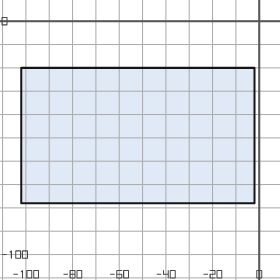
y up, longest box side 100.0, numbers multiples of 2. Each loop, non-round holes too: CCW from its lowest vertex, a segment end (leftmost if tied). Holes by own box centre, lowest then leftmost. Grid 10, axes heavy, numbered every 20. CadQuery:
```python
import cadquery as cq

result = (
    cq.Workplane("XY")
    .moveTo(-102.0, -78.0)
    .lineTo(-2.0, -78.0)
    .lineTo(-2.0, -20.0)
    .lineTo(-102.0, -20.0)
    .close()
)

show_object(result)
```